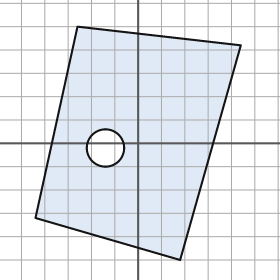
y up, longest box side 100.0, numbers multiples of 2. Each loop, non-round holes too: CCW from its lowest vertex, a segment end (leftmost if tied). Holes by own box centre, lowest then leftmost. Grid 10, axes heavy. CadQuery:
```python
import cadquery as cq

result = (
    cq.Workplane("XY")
    .moveTo(18.0, -50.0)
    .lineTo(44.0, 42.0)
    .lineTo(-26.0, 50.0)
    .lineTo(-44.0, -32.0)
    .close()
    .moveTo(-14.0, -2.0)
    .circle(8.0)
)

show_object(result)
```